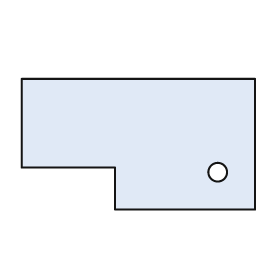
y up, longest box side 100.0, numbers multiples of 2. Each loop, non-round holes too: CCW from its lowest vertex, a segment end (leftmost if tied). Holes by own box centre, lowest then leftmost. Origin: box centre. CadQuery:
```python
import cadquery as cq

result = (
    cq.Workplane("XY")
    .moveTo(-10.0, -28.0)
    .lineTo(50.0, -28.0)
    .lineTo(50.0, 28.0)
    .lineTo(-50.0, 28.0)
    .lineTo(-50.0, -10.0)
    .lineTo(-10.0, -10.0)
    .close()
    .moveTo(34.0, -12.0)
    .circle(4.0)
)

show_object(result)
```